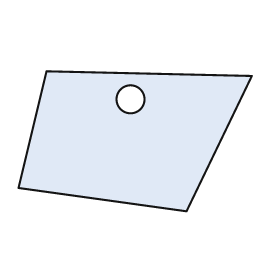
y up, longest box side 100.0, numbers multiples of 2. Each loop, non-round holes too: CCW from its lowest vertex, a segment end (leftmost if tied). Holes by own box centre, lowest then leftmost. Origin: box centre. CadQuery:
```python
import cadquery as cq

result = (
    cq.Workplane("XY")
    .moveTo(22.0, -30.0)
    .lineTo(50.0, 28.0)
    .lineTo(-38.0, 30.0)
    .lineTo(-50.0, -20.0)
    .close()
    .moveTo(-2.0, 18.0)
    .circle(6.0)
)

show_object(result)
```